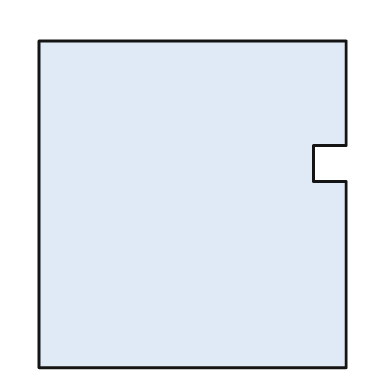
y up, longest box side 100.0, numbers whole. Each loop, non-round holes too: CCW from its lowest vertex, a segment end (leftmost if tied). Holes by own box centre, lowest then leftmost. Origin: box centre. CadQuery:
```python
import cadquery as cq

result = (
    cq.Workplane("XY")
    .moveTo(-47.0, -50.0)
    .lineTo(47.0, -50.0)
    .lineTo(47.0, 7.0)
    .lineTo(37.0, 7.0)
    .lineTo(37.0, 18.0)
    .lineTo(47.0, 18.0)
    .lineTo(47.0, 50.0)
    .lineTo(-47.0, 50.0)
    .close()
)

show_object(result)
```